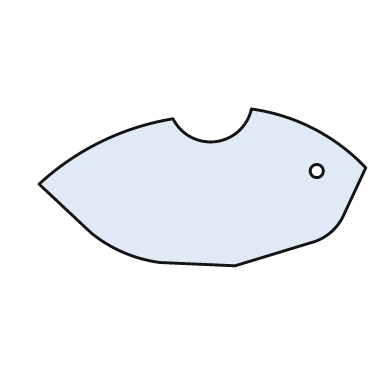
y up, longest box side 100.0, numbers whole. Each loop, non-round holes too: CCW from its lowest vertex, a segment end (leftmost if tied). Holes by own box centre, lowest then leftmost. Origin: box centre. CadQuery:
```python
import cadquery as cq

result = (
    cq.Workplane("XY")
    .moveTo(10.0, -24.0)
    .lineTo(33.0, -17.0)
    .threePointArc((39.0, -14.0), (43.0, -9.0))
    .lineTo(50.0, 6.0)
    .threePointArc((34.0, 18.0), (15.0, 24.0))
    .threePointArc((4.0, 14.0), (-9.0, 21.0))
    .threePointArc((-31.0, 14.0), (-50.0, 1.0))
    .lineTo(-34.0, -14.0)
    .threePointArc((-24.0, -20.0), (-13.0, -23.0))
    .close()
    .moveTo(35.0, 5.0)
    .circle(2.0)
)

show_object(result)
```